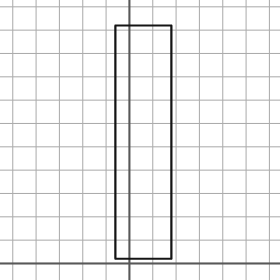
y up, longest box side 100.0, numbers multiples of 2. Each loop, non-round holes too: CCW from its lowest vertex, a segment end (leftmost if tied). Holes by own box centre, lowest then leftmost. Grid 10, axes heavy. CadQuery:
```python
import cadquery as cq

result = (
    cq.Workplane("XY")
    .moveTo(-6.0, 2.0)
    .lineTo(18.0, 2.0)
    .lineTo(18.0, 102.0)
    .lineTo(-6.0, 102.0)
    .close()
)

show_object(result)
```